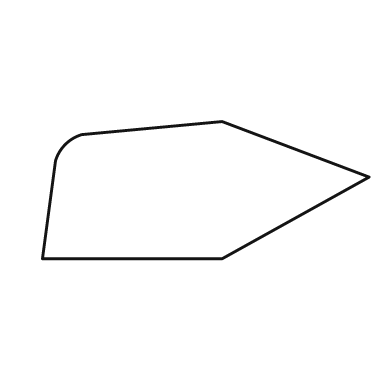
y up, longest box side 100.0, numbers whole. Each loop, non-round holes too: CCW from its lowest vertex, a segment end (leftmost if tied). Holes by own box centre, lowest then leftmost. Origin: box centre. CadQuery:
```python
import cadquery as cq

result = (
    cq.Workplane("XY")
    .moveTo(-50.0, -21.0)
    .lineTo(5.0, -21.0)
    .lineTo(50.0, 4.0)
    .lineTo(5.0, 21.0)
    .lineTo(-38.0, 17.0)
    .threePointArc((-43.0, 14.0), (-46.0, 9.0))
    .close()
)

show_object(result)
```